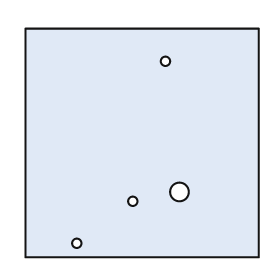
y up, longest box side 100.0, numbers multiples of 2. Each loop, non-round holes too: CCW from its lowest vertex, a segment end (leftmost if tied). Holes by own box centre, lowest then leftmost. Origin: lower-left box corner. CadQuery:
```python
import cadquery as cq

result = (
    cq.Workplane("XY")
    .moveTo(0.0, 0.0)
    .lineTo(100.0, 0.0)
    .lineTo(100.0, 98.0)
    .lineTo(0.0, 98.0)
    .close()
    .moveTo(22.0, 6.0)
    .circle(2.0)
    .moveTo(46.0, 24.0)
    .circle(2.0)
    .moveTo(66.0, 28.0)
    .circle(4.0)
    .moveTo(60.0, 84.0)
    .circle(2.0)
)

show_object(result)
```